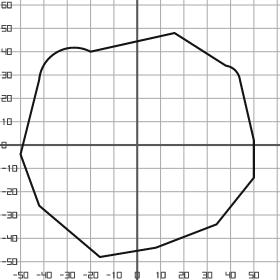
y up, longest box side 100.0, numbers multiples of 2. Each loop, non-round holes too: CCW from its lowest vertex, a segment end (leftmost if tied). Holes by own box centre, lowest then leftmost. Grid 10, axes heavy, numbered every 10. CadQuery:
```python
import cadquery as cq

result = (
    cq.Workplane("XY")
    .moveTo(-16.0, -48.0)
    .lineTo(8.0, -44.0)
    .lineTo(34.0, -34.0)
    .lineTo(50.0, -14.0)
    .lineTo(50.0, 2.0)
    .lineTo(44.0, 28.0)
    .threePointArc((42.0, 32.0), (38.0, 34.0))
    .lineTo(16.0, 48.0)
    .lineTo(-20.0, 40.0)
    .threePointArc((-34.0, 40.0), (-42.0, 28.0))
    .lineTo(-50.0, -4.0)
    .lineTo(-42.0, -26.0)
    .close()
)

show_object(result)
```